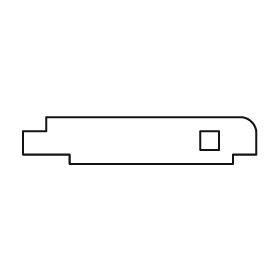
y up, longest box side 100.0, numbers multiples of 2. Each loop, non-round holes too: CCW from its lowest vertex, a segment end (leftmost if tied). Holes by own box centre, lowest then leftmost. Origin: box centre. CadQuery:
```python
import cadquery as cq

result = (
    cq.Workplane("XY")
    .moveTo(-30.0, -10.0)
    .lineTo(40.0, -10.0)
    .lineTo(40.0, -6.0)
    .lineTo(50.0, -6.0)
    .lineTo(50.0, 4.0)
    .threePointArc((48.0, 8.0), (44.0, 10.0))
    .lineTo(-40.0, 10.0)
    .lineTo(-40.0, 4.0)
    .lineTo(-50.0, 4.0)
    .lineTo(-50.0, -6.0)
    .lineTo(-30.0, -6.0)
    .close()
    .moveTo(26.0, -4.0)
    .lineTo(34.0, -4.0)
    .lineTo(34.0, 4.0)
    .lineTo(26.0, 4.0)
    .close()
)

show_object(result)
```